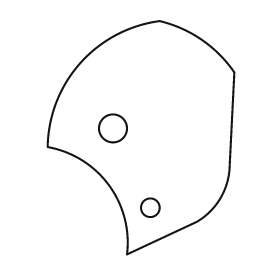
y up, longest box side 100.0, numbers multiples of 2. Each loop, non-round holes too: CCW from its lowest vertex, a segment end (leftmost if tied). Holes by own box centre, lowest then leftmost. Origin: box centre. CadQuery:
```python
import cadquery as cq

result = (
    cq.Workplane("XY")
    .moveTo(-6.0, -50.0)
    .lineTo(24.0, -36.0)
    .threePointArc((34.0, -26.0), (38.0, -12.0))
    .lineTo(40.0, 28.0)
    .threePointArc((26.0, 42.0), (8.0, 50.0))
    .threePointArc((-26.0, 32.0), (-40.0, -4.0))
    .threePointArc((-14.0, -20.0), (-6.0, -50.0))
    .close()
    .moveTo(4.0, -30.0)
    .circle(4.0)
    .moveTo(-12.0, 4.0)
    .circle(6.0)
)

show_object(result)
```